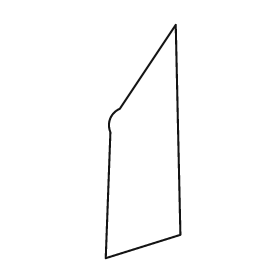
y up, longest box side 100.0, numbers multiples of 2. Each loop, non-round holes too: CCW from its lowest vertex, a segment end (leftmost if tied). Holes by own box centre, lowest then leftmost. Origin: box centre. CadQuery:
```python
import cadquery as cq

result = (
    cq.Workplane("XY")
    .moveTo(-16.0, -50.0)
    .lineTo(16.0, -40.0)
    .lineTo(14.0, 50.0)
    .lineTo(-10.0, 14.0)
    .threePointArc((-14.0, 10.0), (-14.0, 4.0))
    .close()
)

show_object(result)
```